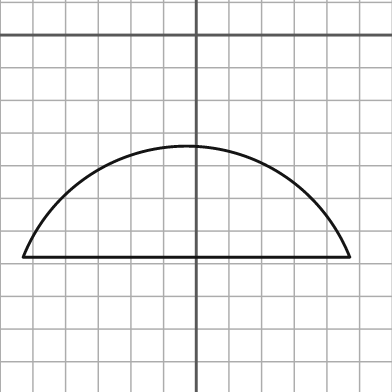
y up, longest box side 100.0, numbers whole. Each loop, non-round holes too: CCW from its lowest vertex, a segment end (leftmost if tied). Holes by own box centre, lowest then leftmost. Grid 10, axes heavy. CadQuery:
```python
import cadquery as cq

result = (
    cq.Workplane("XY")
    .moveTo(-53.0, -68.0)
    .lineTo(47.0, -68.0)
    .threePointArc((-3.0, -34.0), (-53.0, -68.0))
    .close()
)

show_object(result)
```